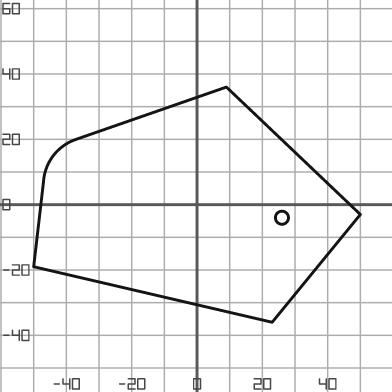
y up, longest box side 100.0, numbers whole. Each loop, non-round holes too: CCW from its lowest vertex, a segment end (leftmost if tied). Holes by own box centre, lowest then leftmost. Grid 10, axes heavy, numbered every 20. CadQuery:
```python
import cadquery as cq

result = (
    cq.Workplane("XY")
    .moveTo(23.0, -36.0)
    .lineTo(50.0, -3.0)
    .lineTo(9.0, 36.0)
    .lineTo(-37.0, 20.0)
    .threePointArc((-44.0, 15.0), (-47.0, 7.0))
    .lineTo(-50.0, -19.0)
    .close()
    .moveTo(26.0, -4.0)
    .circle(2.0)
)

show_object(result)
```